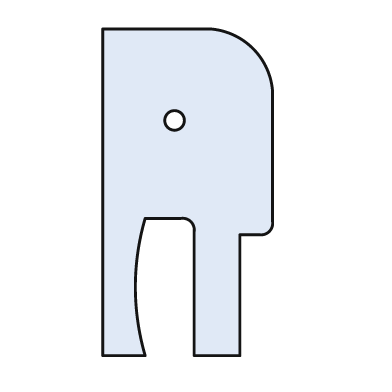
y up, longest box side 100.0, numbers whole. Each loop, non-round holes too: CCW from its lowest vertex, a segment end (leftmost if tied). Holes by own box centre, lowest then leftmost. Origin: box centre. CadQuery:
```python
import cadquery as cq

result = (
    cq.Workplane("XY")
    .moveTo(-26.0, -50.0)
    .lineTo(-13.0, -50.0)
    .threePointArc((-16.0, -29.0), (-13.0, -8.0))
    .lineTo(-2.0, -8.0)
    .threePointArc((1.0, -9.0), (2.0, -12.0))
    .lineTo(2.0, -50.0)
    .lineTo(16.0, -50.0)
    .lineTo(16.0, -13.0)
    .lineTo(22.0, -13.0)
    .threePointArc((25.0, -12.0), (26.0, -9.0))
    .lineTo(26.0, 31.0)
    .threePointArc((20.0, 44.0), (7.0, 50.0))
    .lineTo(-26.0, 50.0)
    .close()
    .moveTo(-4.0, 22.0)
    .circle(3.0)
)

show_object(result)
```